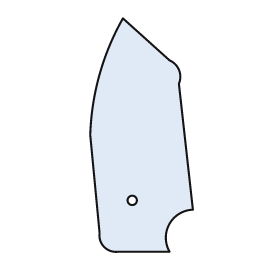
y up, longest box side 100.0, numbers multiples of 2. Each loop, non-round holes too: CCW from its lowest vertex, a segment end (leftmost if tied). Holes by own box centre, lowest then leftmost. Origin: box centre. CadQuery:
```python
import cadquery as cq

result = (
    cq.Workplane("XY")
    .moveTo(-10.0, -50.0)
    .lineTo(12.0, -50.0)
    .threePointArc((12.0, -38.0), (22.0, -32.0))
    .lineTo(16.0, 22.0)
    .threePointArc((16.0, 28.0), (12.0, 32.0))
    .lineTo(-8.0, 50.0)
    .threePointArc((-18.0, 26.0), (-22.0, 0.0))
    .lineTo(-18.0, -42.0)
    .threePointArc((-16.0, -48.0), (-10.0, -50.0))
    .close()
    .moveTo(-4.0, -28.0)
    .circle(2.0)
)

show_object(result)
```